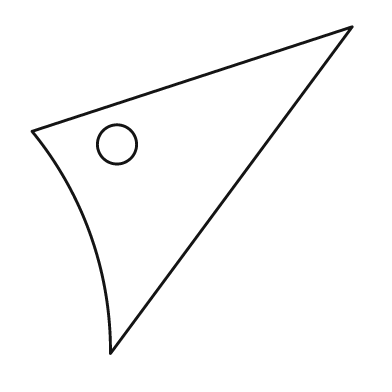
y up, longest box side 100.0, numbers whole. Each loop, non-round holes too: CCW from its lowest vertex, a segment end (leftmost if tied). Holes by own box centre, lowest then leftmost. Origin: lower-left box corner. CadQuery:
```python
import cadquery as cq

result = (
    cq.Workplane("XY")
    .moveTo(24.0, 0.0)
    .lineTo(98.0, 100.0)
    .lineTo(0.0, 68.0)
    .threePointArc((18.0, 36.0), (24.0, 0.0))
    .close()
    .moveTo(26.0, 64.0)
    .circle(6.0)
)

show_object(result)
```